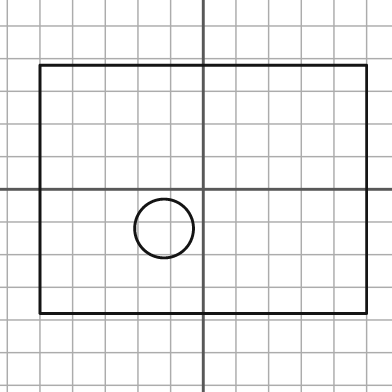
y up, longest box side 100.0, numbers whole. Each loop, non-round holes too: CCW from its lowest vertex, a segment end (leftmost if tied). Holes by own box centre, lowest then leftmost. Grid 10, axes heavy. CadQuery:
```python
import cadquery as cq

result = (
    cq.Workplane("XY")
    .moveTo(-50.0, -38.0)
    .lineTo(50.0, -38.0)
    .lineTo(50.0, 38.0)
    .lineTo(-50.0, 38.0)
    .close()
    .moveTo(-12.0, -12.0)
    .circle(9.0)
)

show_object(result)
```